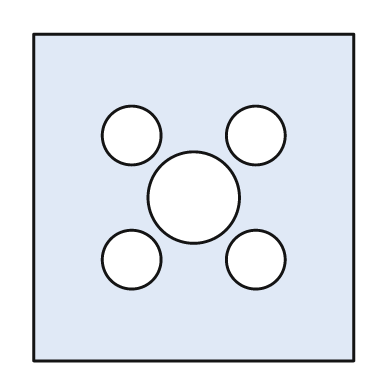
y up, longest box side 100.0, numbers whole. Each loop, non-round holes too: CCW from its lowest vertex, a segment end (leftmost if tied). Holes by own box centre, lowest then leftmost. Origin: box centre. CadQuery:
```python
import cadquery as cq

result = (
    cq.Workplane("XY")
    .moveTo(-49.0, -50.0)
    .lineTo(49.0, -50.0)
    .lineTo(49.0, 50.0)
    .lineTo(-49.0, 50.0)
    .close()
    .moveTo(-19.0, -19.0)
    .circle(9.0)
    .moveTo(19.0, -19.0)
    .circle(9.0)
    .moveTo(0.0, 0.0)
    .circle(14.0)
    .moveTo(-19.0, 19.0)
    .circle(9.0)
    .moveTo(19.0, 19.0)
    .circle(9.0)
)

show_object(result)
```